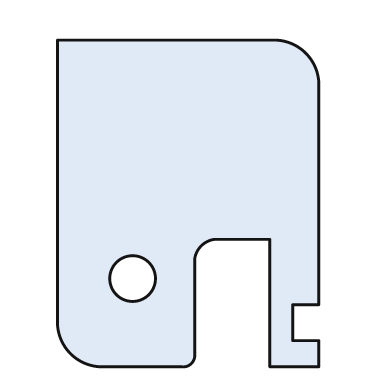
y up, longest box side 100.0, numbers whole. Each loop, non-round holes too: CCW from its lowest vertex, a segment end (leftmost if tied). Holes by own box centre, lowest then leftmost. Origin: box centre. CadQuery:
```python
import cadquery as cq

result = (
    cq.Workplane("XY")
    .moveTo(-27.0, -50.0)
    .lineTo(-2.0, -50.0)
    .threePointArc((1.0, -49.0), (2.0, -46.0))
    .lineTo(2.0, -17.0)
    .threePointArc((4.0, -13.0), (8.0, -11.0))
    .lineTo(25.0, -11.0)
    .lineTo(25.0, -50.0)
    .lineTo(40.0, -50.0)
    .lineTo(40.0, -42.0)
    .lineTo(32.0, -42.0)
    .lineTo(32.0, -31.0)
    .lineTo(40.0, -31.0)
    .lineTo(40.0, 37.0)
    .threePointArc((36.0, 46.0), (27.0, 50.0))
    .lineTo(-40.0, 50.0)
    .lineTo(-40.0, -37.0)
    .threePointArc((-36.0, -46.0), (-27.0, -50.0))
    .close()
    .moveTo(-17.0, -23.0)
    .circle(7.0)
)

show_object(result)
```